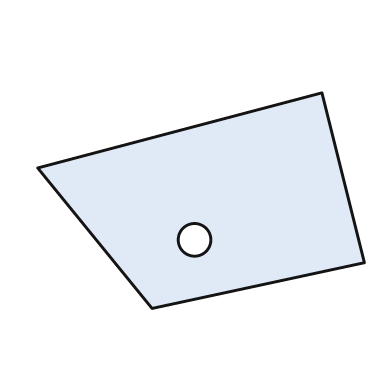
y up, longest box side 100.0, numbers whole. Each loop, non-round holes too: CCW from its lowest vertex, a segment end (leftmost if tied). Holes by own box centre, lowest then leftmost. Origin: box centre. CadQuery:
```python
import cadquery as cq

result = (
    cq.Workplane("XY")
    .moveTo(-15.0, -33.0)
    .lineTo(50.0, -19.0)
    .lineTo(37.0, 33.0)
    .lineTo(-50.0, 10.0)
    .close()
    .moveTo(-2.0, -12.0)
    .circle(5.0)
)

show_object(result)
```